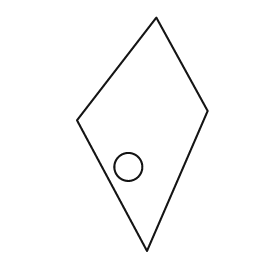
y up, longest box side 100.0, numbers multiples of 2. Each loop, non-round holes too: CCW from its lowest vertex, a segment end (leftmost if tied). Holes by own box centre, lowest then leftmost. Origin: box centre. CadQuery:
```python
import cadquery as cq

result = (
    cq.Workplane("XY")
    .moveTo(2.0, -50.0)
    .lineTo(28.0, 10.0)
    .lineTo(6.0, 50.0)
    .lineTo(-28.0, 6.0)
    .close()
    .moveTo(-6.0, -14.0)
    .circle(6.0)
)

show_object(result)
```